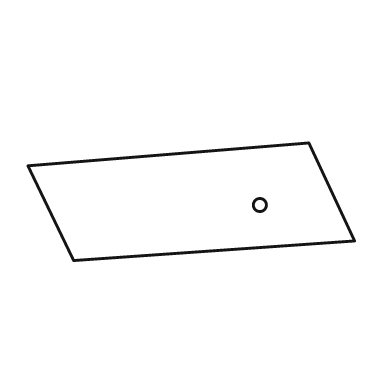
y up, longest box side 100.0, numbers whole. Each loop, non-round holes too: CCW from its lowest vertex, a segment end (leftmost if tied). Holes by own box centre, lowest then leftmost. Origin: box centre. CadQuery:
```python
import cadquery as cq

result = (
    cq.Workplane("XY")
    .moveTo(-36.0, -18.0)
    .lineTo(50.0, -12.0)
    .lineTo(36.0, 18.0)
    .lineTo(-50.0, 11.0)
    .close()
    .moveTo(21.0, -1.0)
    .circle(2.0)
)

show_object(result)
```